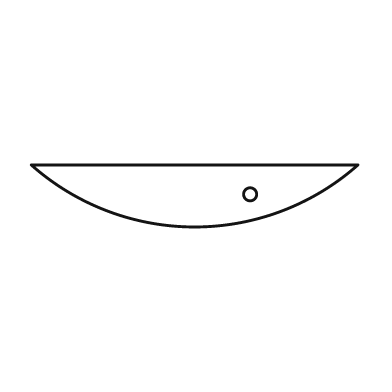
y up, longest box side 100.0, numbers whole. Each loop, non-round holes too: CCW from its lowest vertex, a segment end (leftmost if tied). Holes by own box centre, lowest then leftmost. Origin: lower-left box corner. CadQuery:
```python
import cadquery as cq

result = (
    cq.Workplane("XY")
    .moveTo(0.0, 19.0)
    .threePointArc((50.0, 0.0), (100.0, 19.0))
    .close()
    .moveTo(67.0, 10.0)
    .circle(2.0)
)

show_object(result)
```